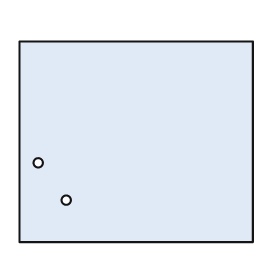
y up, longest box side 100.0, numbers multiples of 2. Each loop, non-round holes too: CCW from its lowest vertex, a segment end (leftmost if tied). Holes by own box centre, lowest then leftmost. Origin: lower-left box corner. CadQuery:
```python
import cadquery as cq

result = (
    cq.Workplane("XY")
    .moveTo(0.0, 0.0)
    .lineTo(100.0, 0.0)
    .lineTo(100.0, 86.0)
    .lineTo(0.0, 86.0)
    .close()
    .moveTo(20.0, 18.0)
    .circle(2.0)
    .moveTo(8.0, 34.0)
    .circle(2.0)
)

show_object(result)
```